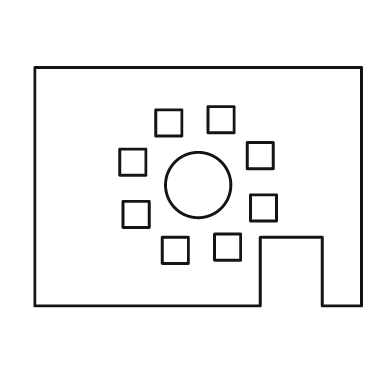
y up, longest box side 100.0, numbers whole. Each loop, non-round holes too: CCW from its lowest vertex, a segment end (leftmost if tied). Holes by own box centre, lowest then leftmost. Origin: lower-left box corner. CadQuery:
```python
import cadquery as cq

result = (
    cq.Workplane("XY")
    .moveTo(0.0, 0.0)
    .lineTo(69.0, 0.0)
    .lineTo(69.0, 21.0)
    .lineTo(88.0, 21.0)
    .lineTo(88.0, 0.0)
    .lineTo(100.0, 0.0)
    .lineTo(100.0, 73.0)
    .lineTo(0.0, 73.0)
    .close()
    .moveTo(39.0, 13.0)
    .lineTo(47.0, 13.0)
    .lineTo(47.0, 21.0)
    .lineTo(39.0, 21.0)
    .close()
    .moveTo(55.0, 14.0)
    .lineTo(63.0, 14.0)
    .lineTo(63.0, 22.0)
    .lineTo(55.0, 22.0)
    .close()
    .moveTo(27.0, 24.0)
    .lineTo(35.0, 24.0)
    .lineTo(35.0, 32.0)
    .lineTo(27.0, 32.0)
    .close()
    .moveTo(66.0, 26.0)
    .lineTo(74.0, 26.0)
    .lineTo(74.0, 34.0)
    .lineTo(66.0, 34.0)
    .close()
    .moveTo(50.0, 37.0)
    .circle(10.0)
    .moveTo(26.0, 40.0)
    .lineTo(34.0, 40.0)
    .lineTo(34.0, 48.0)
    .lineTo(26.0, 48.0)
    .close()
    .moveTo(65.0, 42.0)
    .lineTo(73.0, 42.0)
    .lineTo(73.0, 50.0)
    .lineTo(65.0, 50.0)
    .close()
    .moveTo(37.0, 52.0)
    .lineTo(45.0, 52.0)
    .lineTo(45.0, 60.0)
    .lineTo(37.0, 60.0)
    .close()
    .moveTo(53.0, 53.0)
    .lineTo(61.0, 53.0)
    .lineTo(61.0, 61.0)
    .lineTo(53.0, 61.0)
    .close()
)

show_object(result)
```